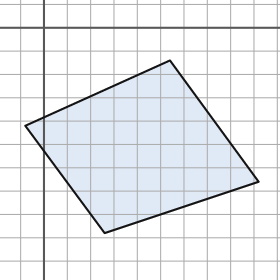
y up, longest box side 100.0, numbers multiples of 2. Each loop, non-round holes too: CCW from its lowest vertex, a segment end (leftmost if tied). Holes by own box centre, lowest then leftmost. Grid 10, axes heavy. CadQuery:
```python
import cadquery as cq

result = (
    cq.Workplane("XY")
    .moveTo(26.0, -88.0)
    .lineTo(92.0, -66.0)
    .lineTo(54.0, -14.0)
    .lineTo(-8.0, -42.0)
    .close()
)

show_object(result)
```